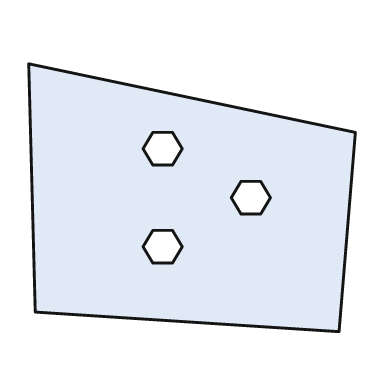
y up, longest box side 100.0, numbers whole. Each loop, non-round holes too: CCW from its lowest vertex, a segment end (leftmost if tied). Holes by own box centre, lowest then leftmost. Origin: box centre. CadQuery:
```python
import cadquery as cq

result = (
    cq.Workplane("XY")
    .moveTo(45.0, -41.0)
    .lineTo(50.0, 20.0)
    .lineTo(-50.0, 41.0)
    .lineTo(-48.0, -35.0)
    .close()
    .moveTo(-12.0, -20.0)
    .lineTo(-6.0, -20.0)
    .lineTo(-3.0, -15.0)
    .lineTo(-6.0, -10.0)
    .lineTo(-12.0, -10.0)
    .lineTo(-15.0, -15.0)
    .close()
    .moveTo(15.0, -5.0)
    .lineTo(21.0, -5.0)
    .lineTo(24.0, 0.0)
    .lineTo(21.0, 5.0)
    .lineTo(15.0, 5.0)
    .lineTo(12.0, 0.0)
    .close()
    .moveTo(-12.0, 10.0)
    .lineTo(-6.0, 10.0)
    .lineTo(-3.0, 15.0)
    .lineTo(-6.0, 20.0)
    .lineTo(-12.0, 20.0)
    .lineTo(-15.0, 15.0)
    .close()
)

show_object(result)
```